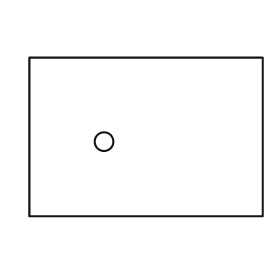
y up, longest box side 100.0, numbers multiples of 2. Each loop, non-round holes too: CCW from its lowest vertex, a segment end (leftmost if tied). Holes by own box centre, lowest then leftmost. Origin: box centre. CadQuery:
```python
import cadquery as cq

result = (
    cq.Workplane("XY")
    .moveTo(-50.0, -34.0)
    .lineTo(50.0, -34.0)
    .lineTo(50.0, 34.0)
    .lineTo(-50.0, 34.0)
    .close()
    .moveTo(-18.0, -2.0)
    .circle(4.0)
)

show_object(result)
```